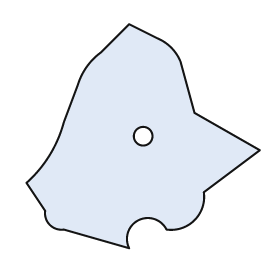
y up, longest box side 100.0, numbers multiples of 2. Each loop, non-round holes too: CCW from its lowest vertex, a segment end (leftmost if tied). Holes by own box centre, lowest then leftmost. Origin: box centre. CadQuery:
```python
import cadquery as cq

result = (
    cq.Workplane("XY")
    .moveTo(-6.0, -48.0)
    .threePointArc((-2.0, -36.0), (10.0, -40.0))
    .threePointArc((22.0, -36.0), (26.0, -24.0))
    .lineTo(50.0, -6.0)
    .lineTo(22.0, 10.0)
    .lineTo(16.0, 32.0)
    .threePointArc((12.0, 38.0), (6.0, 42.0))
    .lineTo(-6.0, 48.0)
    .lineTo(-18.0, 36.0)
    .threePointArc((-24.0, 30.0), (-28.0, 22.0))
    .lineTo(-34.0, 6.0)
    .threePointArc((-40.0, -8.0), (-50.0, -20.0))
    .lineTo(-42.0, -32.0)
    .threePointArc((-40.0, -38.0), (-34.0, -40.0))
    .close()
    .moveTo(0.0, 0.0)
    .circle(4.0)
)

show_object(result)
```